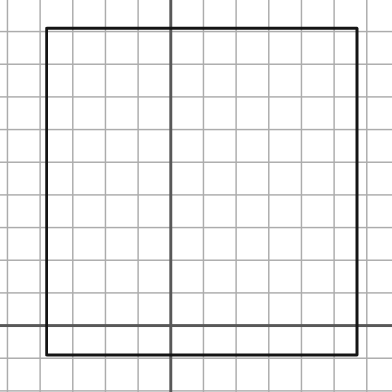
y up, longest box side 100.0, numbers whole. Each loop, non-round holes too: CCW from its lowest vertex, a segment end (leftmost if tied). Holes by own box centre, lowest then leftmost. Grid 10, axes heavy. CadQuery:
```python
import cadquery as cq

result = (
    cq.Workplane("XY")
    .moveTo(-38.0, -9.0)
    .lineTo(57.0, -9.0)
    .lineTo(57.0, 91.0)
    .lineTo(-38.0, 91.0)
    .close()
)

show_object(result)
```